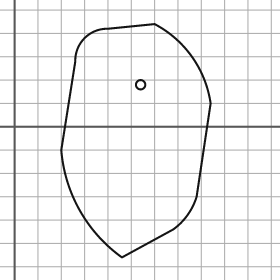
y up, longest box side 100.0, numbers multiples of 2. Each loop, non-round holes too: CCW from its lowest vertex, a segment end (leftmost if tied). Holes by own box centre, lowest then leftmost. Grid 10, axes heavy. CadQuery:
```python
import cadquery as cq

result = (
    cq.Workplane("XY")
    .moveTo(46.0, -56.0)
    .lineTo(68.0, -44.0)
    .threePointArc((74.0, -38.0), (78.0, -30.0))
    .lineTo(84.0, 10.0)
    .threePointArc((76.0, 30.0), (60.0, 44.0))
    .lineTo(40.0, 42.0)
    .threePointArc((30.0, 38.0), (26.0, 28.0))
    .lineTo(20.0, -10.0)
    .threePointArc((28.0, -36.0), (46.0, -56.0))
    .close()
    .moveTo(54.0, 18.0)
    .circle(2.0)
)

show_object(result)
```